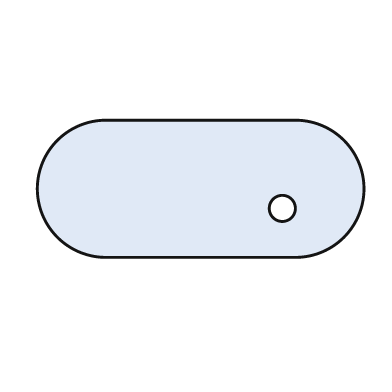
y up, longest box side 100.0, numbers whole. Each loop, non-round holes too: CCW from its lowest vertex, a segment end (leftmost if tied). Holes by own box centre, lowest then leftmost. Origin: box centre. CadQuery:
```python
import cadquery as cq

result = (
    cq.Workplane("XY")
    .moveTo(-29.0, -21.0)
    .lineTo(29.0, -21.0)
    .threePointArc((50.0, 0.0), (29.0, 21.0))
    .lineTo(-29.0, 21.0)
    .threePointArc((-50.0, 0.0), (-29.0, -21.0))
    .close()
    .moveTo(25.0, -6.0)
    .circle(4.0)
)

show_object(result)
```